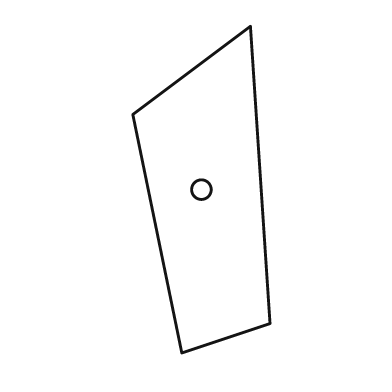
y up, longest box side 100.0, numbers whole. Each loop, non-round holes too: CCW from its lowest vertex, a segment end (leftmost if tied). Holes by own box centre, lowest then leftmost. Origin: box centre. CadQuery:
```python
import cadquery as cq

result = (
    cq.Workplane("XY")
    .moveTo(-6.0, -50.0)
    .lineTo(21.0, -41.0)
    .lineTo(15.0, 50.0)
    .lineTo(-21.0, 23.0)
    .close()
    .moveTo(0.0, 0.0)
    .circle(3.0)
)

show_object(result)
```